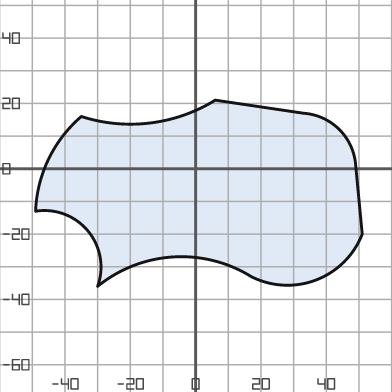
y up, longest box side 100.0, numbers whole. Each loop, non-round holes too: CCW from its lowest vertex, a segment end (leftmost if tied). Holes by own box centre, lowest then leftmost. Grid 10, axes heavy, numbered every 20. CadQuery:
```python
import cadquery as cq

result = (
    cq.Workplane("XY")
    .moveTo(-30.0, -36.0)
    .threePointArc((-7.0, -27.0), (17.0, -33.0))
    .threePointArc((37.0, -34.0), (51.0, -20.0))
    .lineTo(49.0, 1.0)
    .threePointArc((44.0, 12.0), (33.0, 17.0))
    .lineTo(6.0, 21.0)
    .threePointArc((-14.0, 14.0), (-35.0, 16.0))
    .threePointArc((-45.0, 3.0), (-49.0, -13.0))
    .threePointArc((-33.0, -19.0), (-30.0, -36.0))
    .close()
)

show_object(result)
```